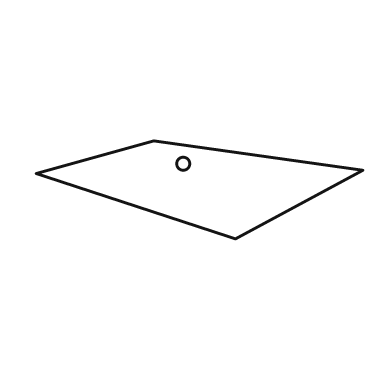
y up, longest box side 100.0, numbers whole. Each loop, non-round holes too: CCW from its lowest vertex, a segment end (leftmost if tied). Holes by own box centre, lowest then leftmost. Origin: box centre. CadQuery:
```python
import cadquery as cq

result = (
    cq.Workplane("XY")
    .moveTo(11.0, -15.0)
    .lineTo(50.0, 6.0)
    .lineTo(-14.0, 15.0)
    .lineTo(-50.0, 5.0)
    .close()
    .moveTo(-5.0, 8.0)
    .circle(2.0)
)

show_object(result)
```